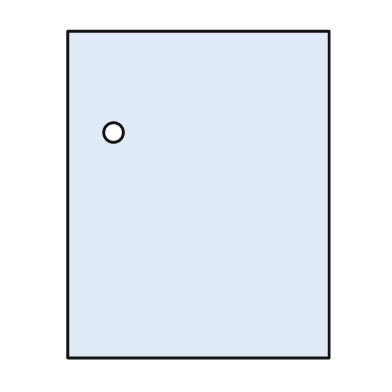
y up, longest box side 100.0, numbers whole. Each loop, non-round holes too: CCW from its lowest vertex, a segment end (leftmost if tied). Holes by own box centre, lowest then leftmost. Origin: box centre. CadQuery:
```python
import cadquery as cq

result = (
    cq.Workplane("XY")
    .moveTo(-40.0, -50.0)
    .lineTo(40.0, -50.0)
    .lineTo(40.0, 50.0)
    .lineTo(-40.0, 50.0)
    .close()
    .moveTo(-26.0, 19.0)
    .circle(3.0)
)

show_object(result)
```